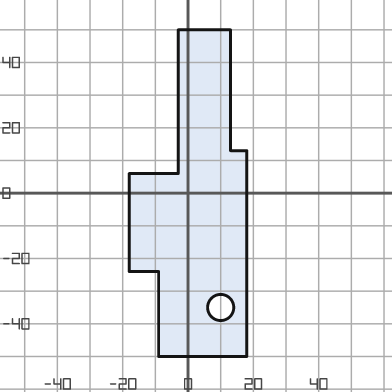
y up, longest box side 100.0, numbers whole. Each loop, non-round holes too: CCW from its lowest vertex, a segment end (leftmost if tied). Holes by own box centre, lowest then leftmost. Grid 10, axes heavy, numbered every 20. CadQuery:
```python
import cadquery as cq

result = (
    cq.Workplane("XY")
    .moveTo(-9.0, -50.0)
    .lineTo(18.0, -50.0)
    .lineTo(18.0, 13.0)
    .lineTo(13.0, 13.0)
    .lineTo(13.0, 50.0)
    .lineTo(-3.0, 50.0)
    .lineTo(-3.0, 6.0)
    .lineTo(-18.0, 6.0)
    .lineTo(-18.0, -24.0)
    .lineTo(-9.0, -24.0)
    .close()
    .moveTo(10.0, -35.0)
    .circle(4.0)
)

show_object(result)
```